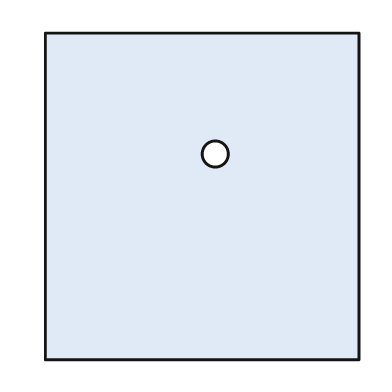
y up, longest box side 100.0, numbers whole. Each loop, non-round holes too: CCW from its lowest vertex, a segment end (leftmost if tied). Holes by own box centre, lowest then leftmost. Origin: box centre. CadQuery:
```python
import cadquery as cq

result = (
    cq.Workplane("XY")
    .moveTo(-48.0, -50.0)
    .lineTo(48.0, -50.0)
    .lineTo(48.0, 50.0)
    .lineTo(-48.0, 50.0)
    .close()
    .moveTo(4.0, 13.0)
    .circle(4.0)
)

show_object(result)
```